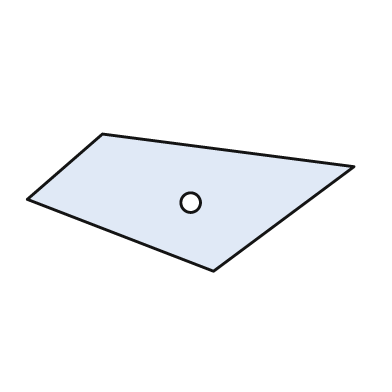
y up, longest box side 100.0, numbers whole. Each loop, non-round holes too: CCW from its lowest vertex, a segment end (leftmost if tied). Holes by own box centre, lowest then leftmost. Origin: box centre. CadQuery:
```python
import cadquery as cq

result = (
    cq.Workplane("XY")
    .moveTo(7.0, -21.0)
    .lineTo(50.0, 11.0)
    .lineTo(-27.0, 21.0)
    .lineTo(-50.0, 1.0)
    .close()
    .moveTo(0.0, 0.0)
    .circle(3.0)
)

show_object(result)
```